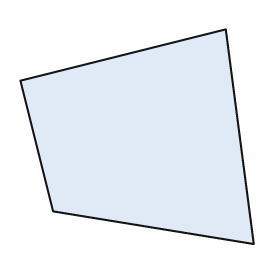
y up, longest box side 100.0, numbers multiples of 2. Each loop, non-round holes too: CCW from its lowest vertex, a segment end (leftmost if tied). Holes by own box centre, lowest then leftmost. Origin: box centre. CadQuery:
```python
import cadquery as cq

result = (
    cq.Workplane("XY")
    .moveTo(50.0, -46.0)
    .lineTo(38.0, 46.0)
    .lineTo(-50.0, 24.0)
    .lineTo(-36.0, -32.0)
    .close()
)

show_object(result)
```